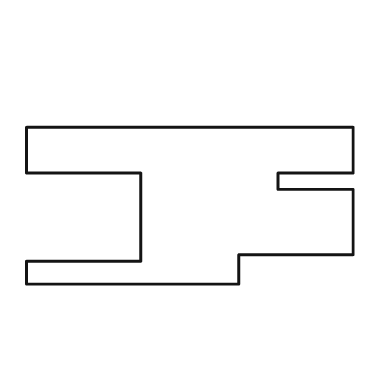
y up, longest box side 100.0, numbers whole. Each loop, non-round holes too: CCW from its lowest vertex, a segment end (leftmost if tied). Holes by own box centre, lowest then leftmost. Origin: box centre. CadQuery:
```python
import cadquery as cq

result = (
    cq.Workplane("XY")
    .moveTo(-50.0, -24.0)
    .lineTo(15.0, -24.0)
    .lineTo(15.0, -15.0)
    .lineTo(50.0, -15.0)
    .lineTo(50.0, 5.0)
    .lineTo(27.0, 5.0)
    .lineTo(27.0, 10.0)
    .lineTo(50.0, 10.0)
    .lineTo(50.0, 24.0)
    .lineTo(-50.0, 24.0)
    .lineTo(-50.0, 10.0)
    .lineTo(-15.0, 10.0)
    .lineTo(-15.0, -17.0)
    .lineTo(-50.0, -17.0)
    .close()
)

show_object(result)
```